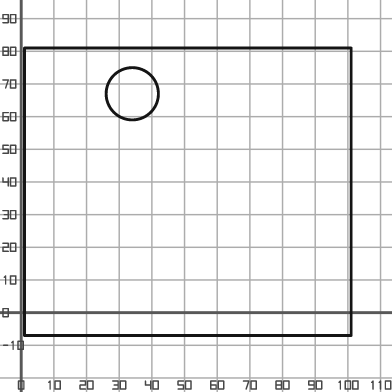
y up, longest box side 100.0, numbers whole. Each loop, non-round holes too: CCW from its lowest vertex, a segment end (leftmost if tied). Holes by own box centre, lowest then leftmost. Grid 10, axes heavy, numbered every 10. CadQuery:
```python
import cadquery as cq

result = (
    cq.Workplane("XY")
    .moveTo(1.0, -7.0)
    .lineTo(101.0, -7.0)
    .lineTo(101.0, 81.0)
    .lineTo(1.0, 81.0)
    .close()
    .moveTo(34.0, 67.0)
    .circle(8.0)
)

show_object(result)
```